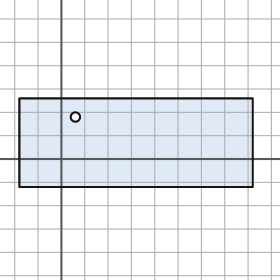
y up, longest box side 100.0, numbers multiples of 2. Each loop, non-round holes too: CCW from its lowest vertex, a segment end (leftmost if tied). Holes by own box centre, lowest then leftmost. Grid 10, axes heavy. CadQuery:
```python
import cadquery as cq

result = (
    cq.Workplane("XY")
    .moveTo(-18.0, -12.0)
    .lineTo(82.0, -12.0)
    .lineTo(82.0, 26.0)
    .lineTo(-18.0, 26.0)
    .close()
    .moveTo(6.0, 18.0)
    .circle(2.0)
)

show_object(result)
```